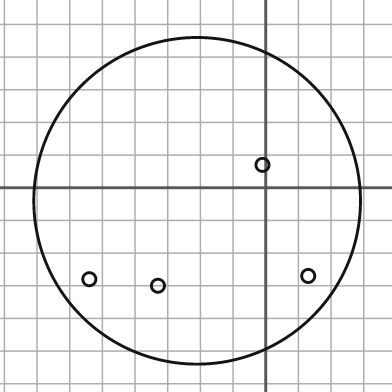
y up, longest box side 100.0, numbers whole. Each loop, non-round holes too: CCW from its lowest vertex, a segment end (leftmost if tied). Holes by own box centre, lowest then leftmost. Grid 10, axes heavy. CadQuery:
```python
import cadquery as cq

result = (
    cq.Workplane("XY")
    .moveTo(-21.0, -4.0)
    .circle(50.0)
    .moveTo(-33.0, -30.0)
    .circle(2.0)
    .moveTo(-54.0, -28.0)
    .circle(2.0)
    .moveTo(13.0, -27.0)
    .circle(2.0)
    .moveTo(-1.0, 7.0)
    .circle(2.0)
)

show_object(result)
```